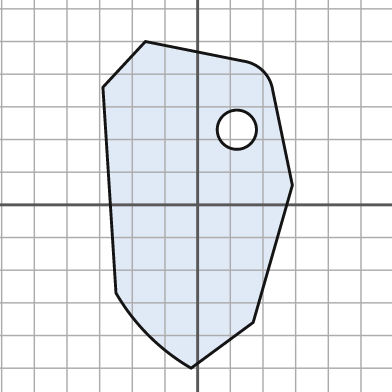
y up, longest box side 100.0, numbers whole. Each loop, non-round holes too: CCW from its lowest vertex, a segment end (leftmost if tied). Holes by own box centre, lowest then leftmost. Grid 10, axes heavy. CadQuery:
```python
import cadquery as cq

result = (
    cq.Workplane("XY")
    .moveTo(-2.0, -50.0)
    .lineTo(17.0, -36.0)
    .lineTo(29.0, 6.0)
    .lineTo(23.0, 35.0)
    .threePointArc((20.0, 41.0), (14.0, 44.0))
    .lineTo(-16.0, 50.0)
    .lineTo(-29.0, 36.0)
    .lineTo(-25.0, -27.0)
    .threePointArc((-15.0, -40.0), (-2.0, -50.0))
    .close()
    .moveTo(12.0, 23.0)
    .circle(6.0)
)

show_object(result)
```